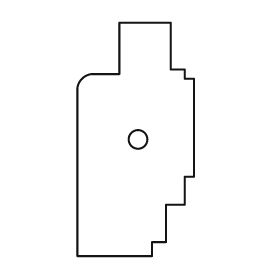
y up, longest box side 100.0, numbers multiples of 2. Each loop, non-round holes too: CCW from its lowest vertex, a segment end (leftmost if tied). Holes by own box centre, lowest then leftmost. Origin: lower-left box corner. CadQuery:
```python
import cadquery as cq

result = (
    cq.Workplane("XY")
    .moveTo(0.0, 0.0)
    .lineTo(32.0, 0.0)
    .lineTo(32.0, 6.0)
    .lineTo(38.0, 6.0)
    .lineTo(38.0, 22.0)
    .lineTo(46.0, 22.0)
    .lineTo(46.0, 34.0)
    .lineTo(50.0, 34.0)
    .lineTo(50.0, 76.0)
    .lineTo(46.0, 76.0)
    .lineTo(46.0, 80.0)
    .lineTo(40.0, 80.0)
    .lineTo(40.0, 100.0)
    .lineTo(18.0, 100.0)
    .lineTo(18.0, 78.0)
    .lineTo(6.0, 78.0)
    .threePointArc((2.0, 76.0), (0.0, 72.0))
    .close()
    .moveTo(26.0, 50.0)
    .circle(4.0)
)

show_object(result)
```